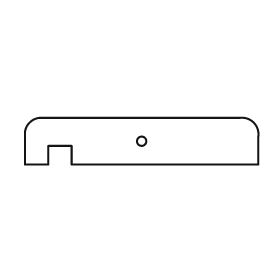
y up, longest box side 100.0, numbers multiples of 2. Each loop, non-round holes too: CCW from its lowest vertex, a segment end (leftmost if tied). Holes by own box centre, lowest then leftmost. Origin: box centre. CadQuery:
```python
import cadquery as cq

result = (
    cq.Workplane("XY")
    .moveTo(-50.0, -10.0)
    .lineTo(-40.0, -10.0)
    .lineTo(-40.0, -2.0)
    .lineTo(-30.0, -2.0)
    .lineTo(-30.0, -10.0)
    .lineTo(50.0, -10.0)
    .lineTo(50.0, 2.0)
    .threePointArc((48.0, 8.0), (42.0, 10.0))
    .lineTo(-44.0, 10.0)
    .threePointArc((-48.0, 8.0), (-50.0, 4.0))
    .close()
    .moveTo(0.0, 0.0)
    .circle(2.0)
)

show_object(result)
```